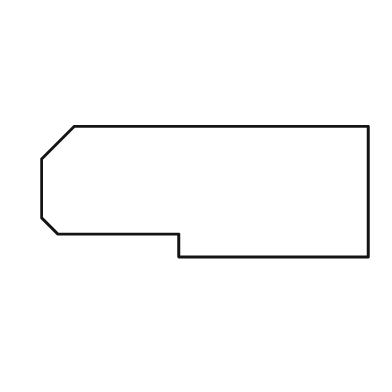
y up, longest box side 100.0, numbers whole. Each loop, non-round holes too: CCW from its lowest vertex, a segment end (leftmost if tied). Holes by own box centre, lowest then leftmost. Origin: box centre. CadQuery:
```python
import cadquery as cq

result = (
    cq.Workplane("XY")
    .moveTo(-8.0, -20.0)
    .lineTo(50.0, -20.0)
    .lineTo(50.0, 20.0)
    .lineTo(-40.0, 20.0)
    .lineTo(-50.0, 10.0)
    .lineTo(-50.0, -8.0)
    .lineTo(-45.0, -13.0)
    .lineTo(-8.0, -13.0)
    .close()
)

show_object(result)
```